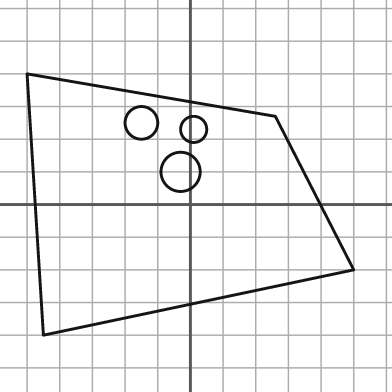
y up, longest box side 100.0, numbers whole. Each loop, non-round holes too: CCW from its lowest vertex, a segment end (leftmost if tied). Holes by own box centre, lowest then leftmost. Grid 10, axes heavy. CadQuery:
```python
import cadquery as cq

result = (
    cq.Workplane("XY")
    .moveTo(-45.0, -40.0)
    .lineTo(50.0, -20.0)
    .lineTo(26.0, 27.0)
    .lineTo(-50.0, 40.0)
    .close()
    .moveTo(-3.0, 10.0)
    .circle(6.0)
    .moveTo(1.0, 23.0)
    .circle(4.0)
    .moveTo(-15.0, 25.0)
    .circle(5.0)
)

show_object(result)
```